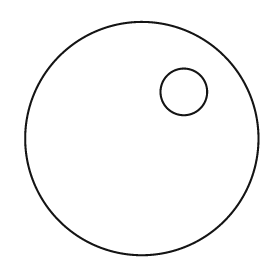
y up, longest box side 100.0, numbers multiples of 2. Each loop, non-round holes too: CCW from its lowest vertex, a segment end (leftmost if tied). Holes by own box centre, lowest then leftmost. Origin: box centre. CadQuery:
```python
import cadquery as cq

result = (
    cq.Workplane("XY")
    .moveTo(0.0, 0.0)
    .circle(50.0)
    .moveTo(18.0, 20.0)
    .circle(10.0)
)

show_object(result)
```